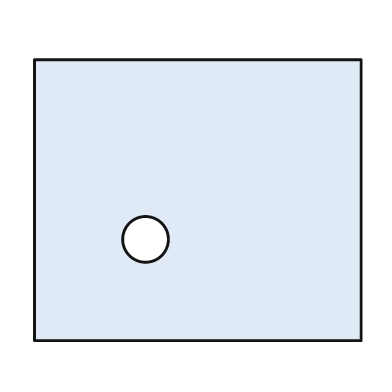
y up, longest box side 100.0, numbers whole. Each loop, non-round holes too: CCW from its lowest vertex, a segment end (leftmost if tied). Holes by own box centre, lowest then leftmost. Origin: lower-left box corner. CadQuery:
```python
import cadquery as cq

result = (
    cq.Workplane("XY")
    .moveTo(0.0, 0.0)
    .lineTo(100.0, 0.0)
    .lineTo(100.0, 86.0)
    .lineTo(0.0, 86.0)
    .close()
    .moveTo(34.0, 31.0)
    .circle(7.0)
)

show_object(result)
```